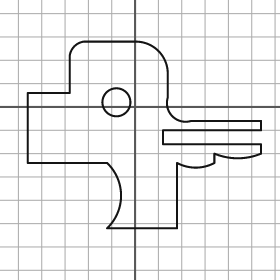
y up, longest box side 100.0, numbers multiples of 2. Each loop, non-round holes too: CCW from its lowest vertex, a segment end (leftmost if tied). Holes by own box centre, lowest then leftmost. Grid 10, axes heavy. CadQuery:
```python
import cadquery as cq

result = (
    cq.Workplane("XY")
    .moveTo(-12.0, -52.0)
    .lineTo(18.0, -52.0)
    .lineTo(18.0, -24.0)
    .threePointArc((26.0, -26.0), (34.0, -24.0))
    .lineTo(34.0, -20.0)
    .threePointArc((44.0, -22.0), (54.0, -20.0))
    .lineTo(54.0, -16.0)
    .lineTo(12.0, -16.0)
    .lineTo(12.0, -10.0)
    .lineTo(54.0, -10.0)
    .lineTo(54.0, -6.0)
    .lineTo(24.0, -6.0)
    .threePointArc((16.0, -4.0), (14.0, 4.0))
    .lineTo(14.0, 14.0)
    .threePointArc((10.0, 24.0), (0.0, 28.0))
    .lineTo(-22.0, 28.0)
    .threePointArc((-26.0, 26.0), (-28.0, 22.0))
    .lineTo(-28.0, 6.0)
    .lineTo(-46.0, 6.0)
    .lineTo(-46.0, -24.0)
    .lineTo(-12.0, -24.0)
    .threePointArc((-6.0, -38.0), (-12.0, -52.0))
    .close()
    .moveTo(-8.0, 2.0)
    .circle(6.0)
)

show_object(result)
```